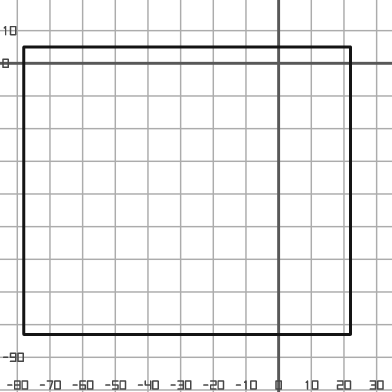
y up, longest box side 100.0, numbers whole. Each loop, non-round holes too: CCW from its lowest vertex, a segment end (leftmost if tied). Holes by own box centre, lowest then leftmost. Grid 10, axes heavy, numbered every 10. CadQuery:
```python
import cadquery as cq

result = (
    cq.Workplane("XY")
    .moveTo(-78.0, -83.0)
    .lineTo(22.0, -83.0)
    .lineTo(22.0, 5.0)
    .lineTo(-78.0, 5.0)
    .close()
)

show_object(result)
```